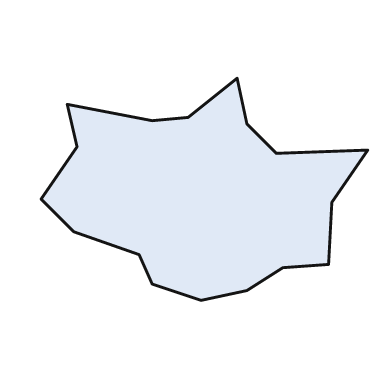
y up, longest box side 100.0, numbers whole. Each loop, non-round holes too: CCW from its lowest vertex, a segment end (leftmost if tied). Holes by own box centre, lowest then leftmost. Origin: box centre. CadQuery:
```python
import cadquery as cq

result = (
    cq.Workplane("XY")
    .moveTo(-1.0, -34.0)
    .lineTo(13.0, -31.0)
    .lineTo(24.0, -24.0)
    .lineTo(38.0, -23.0)
    .lineTo(39.0, -4.0)
    .lineTo(50.0, 12.0)
    .lineTo(22.0, 11.0)
    .lineTo(13.0, 20.0)
    .lineTo(10.0, 34.0)
    .lineTo(-5.0, 22.0)
    .lineTo(-16.0, 21.0)
    .lineTo(-42.0, 26.0)
    .lineTo(-39.0, 13.0)
    .lineTo(-50.0, -3.0)
    .lineTo(-40.0, -13.0)
    .lineTo(-20.0, -20.0)
    .lineTo(-16.0, -29.0)
    .close()
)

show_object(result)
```